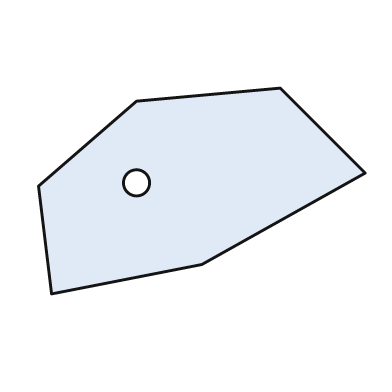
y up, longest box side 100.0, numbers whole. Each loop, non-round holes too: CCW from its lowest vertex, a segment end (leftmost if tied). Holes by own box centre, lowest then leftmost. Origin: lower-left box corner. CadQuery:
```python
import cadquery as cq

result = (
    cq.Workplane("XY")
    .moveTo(4.0, 0.0)
    .lineTo(50.0, 9.0)
    .lineTo(100.0, 37.0)
    .lineTo(74.0, 63.0)
    .lineTo(30.0, 59.0)
    .lineTo(0.0, 33.0)
    .close()
    .moveTo(30.0, 34.0)
    .circle(4.0)
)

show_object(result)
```